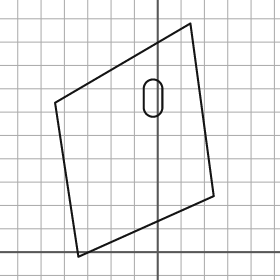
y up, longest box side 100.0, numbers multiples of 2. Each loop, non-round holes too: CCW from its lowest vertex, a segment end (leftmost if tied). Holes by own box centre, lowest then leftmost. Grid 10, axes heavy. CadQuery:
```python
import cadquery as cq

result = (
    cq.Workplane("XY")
    .moveTo(-34.0, -2.0)
    .lineTo(24.0, 24.0)
    .lineTo(14.0, 98.0)
    .lineTo(-44.0, 64.0)
    .close()
    .moveTo(-6.0, 62.0)
    .threePointArc((-2.0, 58.0), (2.0, 62.0))
    .lineTo(2.0, 70.0)
    .threePointArc((-2.0, 74.0), (-6.0, 70.0))
    .close()
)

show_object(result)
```